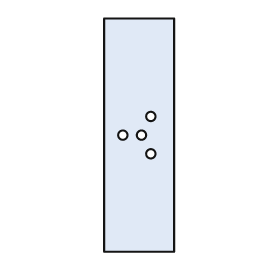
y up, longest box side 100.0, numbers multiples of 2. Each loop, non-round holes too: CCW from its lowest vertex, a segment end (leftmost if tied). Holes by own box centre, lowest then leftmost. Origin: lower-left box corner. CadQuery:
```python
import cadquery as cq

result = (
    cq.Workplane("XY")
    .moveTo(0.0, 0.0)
    .lineTo(30.0, 0.0)
    .lineTo(30.0, 100.0)
    .lineTo(0.0, 100.0)
    .close()
    .moveTo(20.0, 42.0)
    .circle(2.0)
    .moveTo(8.0, 50.0)
    .circle(2.0)
    .moveTo(16.0, 50.0)
    .circle(2.0)
    .moveTo(20.0, 58.0)
    .circle(2.0)
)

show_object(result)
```